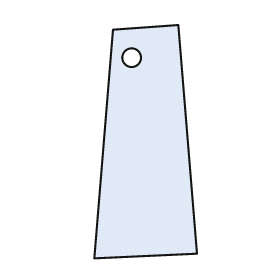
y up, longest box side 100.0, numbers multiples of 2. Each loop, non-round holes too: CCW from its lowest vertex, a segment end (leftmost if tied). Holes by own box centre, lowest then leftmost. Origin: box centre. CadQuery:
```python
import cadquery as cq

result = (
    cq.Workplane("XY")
    .moveTo(-22.0, -50.0)
    .lineTo(22.0, -48.0)
    .lineTo(14.0, 50.0)
    .lineTo(-14.0, 48.0)
    .close()
    .moveTo(-6.0, 36.0)
    .circle(4.0)
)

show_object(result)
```